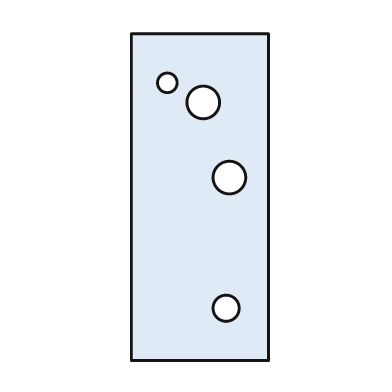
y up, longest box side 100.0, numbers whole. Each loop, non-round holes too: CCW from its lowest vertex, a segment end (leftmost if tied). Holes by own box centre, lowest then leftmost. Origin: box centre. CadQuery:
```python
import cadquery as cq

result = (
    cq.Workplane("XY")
    .moveTo(-21.0, -50.0)
    .lineTo(21.0, -50.0)
    .lineTo(21.0, 50.0)
    .lineTo(-21.0, 50.0)
    .close()
    .moveTo(8.0, -34.0)
    .circle(4.0)
    .moveTo(9.0, 6.0)
    .circle(5.0)
    .moveTo(1.0, 29.0)
    .circle(5.0)
    .moveTo(-10.0, 35.0)
    .circle(3.0)
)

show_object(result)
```